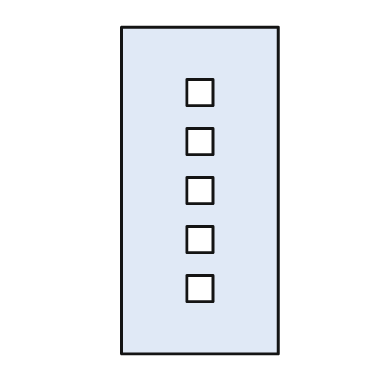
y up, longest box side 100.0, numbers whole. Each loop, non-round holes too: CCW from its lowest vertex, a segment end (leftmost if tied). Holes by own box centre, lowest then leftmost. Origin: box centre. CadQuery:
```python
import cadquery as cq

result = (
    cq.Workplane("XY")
    .moveTo(-24.0, -50.0)
    .lineTo(24.0, -50.0)
    .lineTo(24.0, 50.0)
    .lineTo(-24.0, 50.0)
    .close()
    .moveTo(-4.0, -34.0)
    .lineTo(4.0, -34.0)
    .lineTo(4.0, -26.0)
    .lineTo(-4.0, -26.0)
    .close()
    .moveTo(-4.0, -19.0)
    .lineTo(4.0, -19.0)
    .lineTo(4.0, -11.0)
    .lineTo(-4.0, -11.0)
    .close()
    .moveTo(-4.0, -4.0)
    .lineTo(4.0, -4.0)
    .lineTo(4.0, 4.0)
    .lineTo(-4.0, 4.0)
    .close()
    .moveTo(-4.0, 11.0)
    .lineTo(4.0, 11.0)
    .lineTo(4.0, 19.0)
    .lineTo(-4.0, 19.0)
    .close()
    .moveTo(-4.0, 26.0)
    .lineTo(4.0, 26.0)
    .lineTo(4.0, 34.0)
    .lineTo(-4.0, 34.0)
    .close()
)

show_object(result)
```